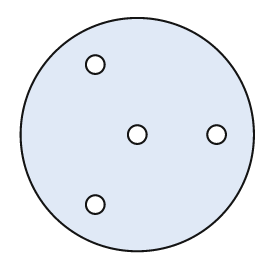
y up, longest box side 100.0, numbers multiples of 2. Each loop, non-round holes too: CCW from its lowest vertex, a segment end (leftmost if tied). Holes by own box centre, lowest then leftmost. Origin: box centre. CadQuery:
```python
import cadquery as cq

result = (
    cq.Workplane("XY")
    .moveTo(0.0, 0.0)
    .circle(50.0)
    .moveTo(-18.0, -30.0)
    .circle(4.0)
    .moveTo(0.0, 0.0)
    .circle(4.0)
    .moveTo(34.0, 0.0)
    .circle(4.0)
    .moveTo(-18.0, 30.0)
    .circle(4.0)
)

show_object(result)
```